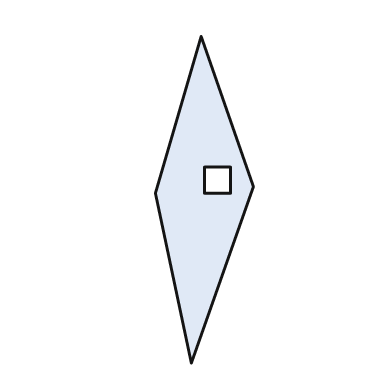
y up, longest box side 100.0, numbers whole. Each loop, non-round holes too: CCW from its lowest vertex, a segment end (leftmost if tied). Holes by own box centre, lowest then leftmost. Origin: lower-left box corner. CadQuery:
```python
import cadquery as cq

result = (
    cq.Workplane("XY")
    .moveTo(11.0, 0.0)
    .lineTo(30.0, 54.0)
    .lineTo(14.0, 100.0)
    .lineTo(0.0, 52.0)
    .close()
    .moveTo(15.0, 52.0)
    .lineTo(23.0, 52.0)
    .lineTo(23.0, 60.0)
    .lineTo(15.0, 60.0)
    .close()
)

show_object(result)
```